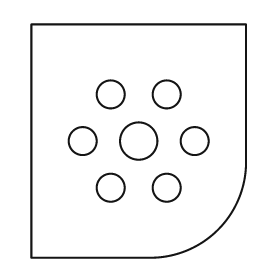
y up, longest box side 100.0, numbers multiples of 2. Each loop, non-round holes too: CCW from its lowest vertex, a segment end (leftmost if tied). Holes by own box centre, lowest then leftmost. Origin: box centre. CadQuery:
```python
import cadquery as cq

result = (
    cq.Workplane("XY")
    .moveTo(-46.0, -50.0)
    .lineTo(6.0, -50.0)
    .threePointArc((34.0, -38.0), (46.0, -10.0))
    .lineTo(46.0, 50.0)
    .lineTo(-46.0, 50.0)
    .close()
    .moveTo(-12.0, -20.0)
    .circle(6.0)
    .moveTo(12.0, -20.0)
    .circle(6.0)
    .moveTo(-24.0, 0.0)
    .circle(6.0)
    .moveTo(0.0, 0.0)
    .circle(8.0)
    .moveTo(24.0, 0.0)
    .circle(6.0)
    .moveTo(-12.0, 20.0)
    .circle(6.0)
    .moveTo(12.0, 20.0)
    .circle(6.0)
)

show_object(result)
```